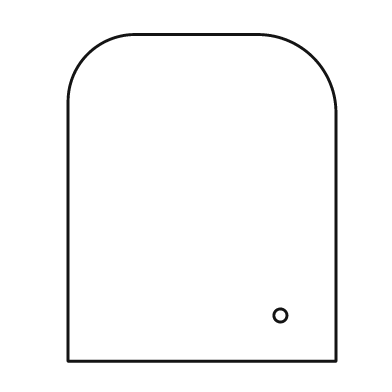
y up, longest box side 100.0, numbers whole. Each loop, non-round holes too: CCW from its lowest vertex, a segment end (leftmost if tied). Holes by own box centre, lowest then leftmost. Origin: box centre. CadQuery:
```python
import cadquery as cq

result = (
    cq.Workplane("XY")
    .moveTo(-41.0, -50.0)
    .lineTo(41.0, -50.0)
    .lineTo(41.0, 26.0)
    .threePointArc((34.0, 43.0), (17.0, 50.0))
    .lineTo(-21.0, 50.0)
    .threePointArc((-35.0, 44.0), (-41.0, 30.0))
    .close()
    .moveTo(24.0, -36.0)
    .circle(2.0)
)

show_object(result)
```